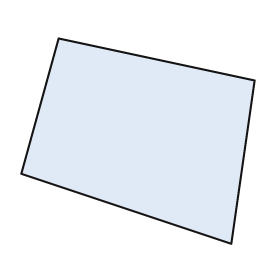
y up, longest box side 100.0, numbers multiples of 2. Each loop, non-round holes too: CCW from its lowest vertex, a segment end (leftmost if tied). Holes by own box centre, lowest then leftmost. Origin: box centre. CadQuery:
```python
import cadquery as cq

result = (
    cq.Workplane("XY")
    .moveTo(40.0, -44.0)
    .lineTo(50.0, 26.0)
    .lineTo(-34.0, 44.0)
    .lineTo(-50.0, -14.0)
    .close()
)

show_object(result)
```